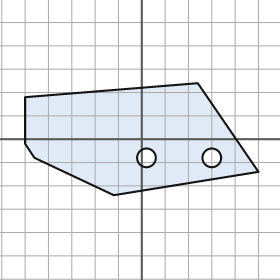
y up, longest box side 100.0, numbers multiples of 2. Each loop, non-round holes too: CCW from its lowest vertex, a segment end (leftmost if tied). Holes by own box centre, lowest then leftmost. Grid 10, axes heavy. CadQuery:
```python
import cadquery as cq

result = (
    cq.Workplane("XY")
    .moveTo(-12.0, -24.0)
    .lineTo(50.0, -14.0)
    .lineTo(24.0, 24.0)
    .lineTo(-50.0, 18.0)
    .lineTo(-50.0, -2.0)
    .lineTo(-46.0, -8.0)
    .close()
    .moveTo(2.0, -8.0)
    .circle(4.0)
    .moveTo(30.0, -8.0)
    .circle(4.0)
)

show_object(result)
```